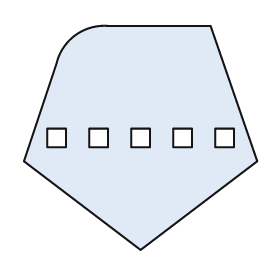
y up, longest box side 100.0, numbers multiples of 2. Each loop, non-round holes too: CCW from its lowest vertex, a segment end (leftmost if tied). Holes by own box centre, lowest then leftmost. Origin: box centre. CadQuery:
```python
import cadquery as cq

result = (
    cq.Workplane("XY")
    .moveTo(0.0, -48.0)
    .lineTo(50.0, -10.0)
    .lineTo(30.0, 48.0)
    .lineTo(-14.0, 48.0)
    .threePointArc((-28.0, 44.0), (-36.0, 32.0))
    .lineTo(-50.0, -10.0)
    .close()
    .moveTo(-40.0, -4.0)
    .lineTo(-32.0, -4.0)
    .lineTo(-32.0, 4.0)
    .lineTo(-40.0, 4.0)
    .close()
    .moveTo(-22.0, -4.0)
    .lineTo(-14.0, -4.0)
    .lineTo(-14.0, 4.0)
    .lineTo(-22.0, 4.0)
    .close()
    .moveTo(-4.0, -4.0)
    .lineTo(4.0, -4.0)
    .lineTo(4.0, 4.0)
    .lineTo(-4.0, 4.0)
    .close()
    .moveTo(14.0, -4.0)
    .lineTo(22.0, -4.0)
    .lineTo(22.0, 4.0)
    .lineTo(14.0, 4.0)
    .close()
    .moveTo(32.0, -4.0)
    .lineTo(40.0, -4.0)
    .lineTo(40.0, 4.0)
    .lineTo(32.0, 4.0)
    .close()
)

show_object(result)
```